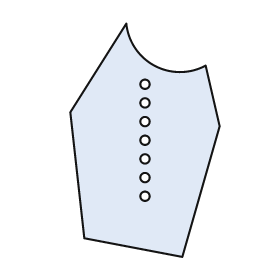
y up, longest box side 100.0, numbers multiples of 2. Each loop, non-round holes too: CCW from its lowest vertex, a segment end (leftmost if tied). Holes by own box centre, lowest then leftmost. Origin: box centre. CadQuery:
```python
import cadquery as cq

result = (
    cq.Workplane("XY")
    .moveTo(16.0, -50.0)
    .lineTo(32.0, 6.0)
    .lineTo(26.0, 32.0)
    .threePointArc((4.0, 32.0), (-8.0, 50.0))
    .lineTo(-32.0, 12.0)
    .lineTo(-26.0, -42.0)
    .close()
    .moveTo(0.0, -24.0)
    .circle(2.0)
    .moveTo(0.0, -16.0)
    .circle(2.0)
    .moveTo(0.0, -8.0)
    .circle(2.0)
    .moveTo(0.0, 0.0)
    .circle(2.0)
    .moveTo(0.0, 8.0)
    .circle(2.0)
    .moveTo(0.0, 16.0)
    .circle(2.0)
    .moveTo(0.0, 24.0)
    .circle(2.0)
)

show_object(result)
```